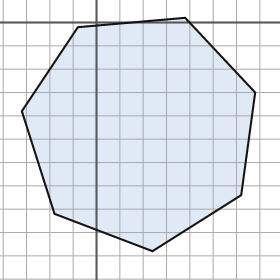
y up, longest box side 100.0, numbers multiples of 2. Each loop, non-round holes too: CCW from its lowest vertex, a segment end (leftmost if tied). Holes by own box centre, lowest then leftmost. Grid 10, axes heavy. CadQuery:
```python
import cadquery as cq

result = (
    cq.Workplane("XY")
    .moveTo(24.0, -98.0)
    .lineTo(62.0, -74.0)
    .lineTo(68.0, -30.0)
    .lineTo(38.0, 2.0)
    .lineTo(-8.0, -2.0)
    .lineTo(-32.0, -38.0)
    .lineTo(-18.0, -82.0)
    .close()
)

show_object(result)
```